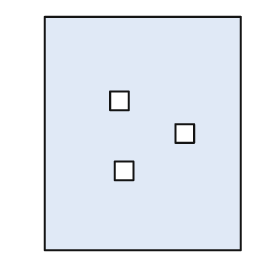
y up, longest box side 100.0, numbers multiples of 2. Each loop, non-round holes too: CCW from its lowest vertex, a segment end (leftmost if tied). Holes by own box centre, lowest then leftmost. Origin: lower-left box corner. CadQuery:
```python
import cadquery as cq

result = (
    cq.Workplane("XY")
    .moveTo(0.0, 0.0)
    .lineTo(84.0, 0.0)
    .lineTo(84.0, 100.0)
    .lineTo(0.0, 100.0)
    .close()
    .moveTo(30.0, 30.0)
    .lineTo(38.0, 30.0)
    .lineTo(38.0, 38.0)
    .lineTo(30.0, 38.0)
    .close()
    .moveTo(56.0, 46.0)
    .lineTo(64.0, 46.0)
    .lineTo(64.0, 54.0)
    .lineTo(56.0, 54.0)
    .close()
    .moveTo(28.0, 60.0)
    .lineTo(36.0, 60.0)
    .lineTo(36.0, 68.0)
    .lineTo(28.0, 68.0)
    .close()
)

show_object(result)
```